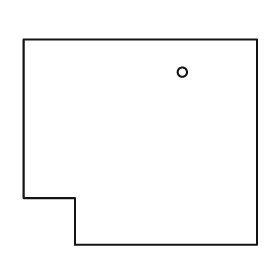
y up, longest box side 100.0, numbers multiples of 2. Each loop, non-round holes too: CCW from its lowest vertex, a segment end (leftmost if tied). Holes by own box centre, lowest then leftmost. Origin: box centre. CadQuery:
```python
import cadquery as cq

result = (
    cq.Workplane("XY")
    .moveTo(-28.0, -44.0)
    .lineTo(50.0, -44.0)
    .lineTo(50.0, 44.0)
    .lineTo(-50.0, 44.0)
    .lineTo(-50.0, -24.0)
    .lineTo(-28.0, -24.0)
    .close()
    .moveTo(18.0, 30.0)
    .circle(2.0)
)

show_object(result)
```